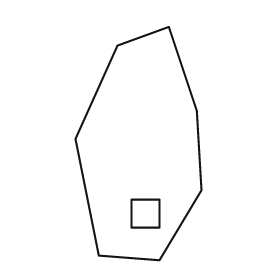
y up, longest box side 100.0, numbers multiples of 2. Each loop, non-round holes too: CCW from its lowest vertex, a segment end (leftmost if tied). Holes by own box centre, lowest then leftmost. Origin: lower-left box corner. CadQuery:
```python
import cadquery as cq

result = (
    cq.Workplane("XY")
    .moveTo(36.0, 0.0)
    .lineTo(54.0, 30.0)
    .lineTo(52.0, 64.0)
    .lineTo(40.0, 100.0)
    .lineTo(18.0, 92.0)
    .lineTo(0.0, 52.0)
    .lineTo(10.0, 2.0)
    .close()
    .moveTo(24.0, 14.0)
    .lineTo(36.0, 14.0)
    .lineTo(36.0, 26.0)
    .lineTo(24.0, 26.0)
    .close()
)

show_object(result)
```